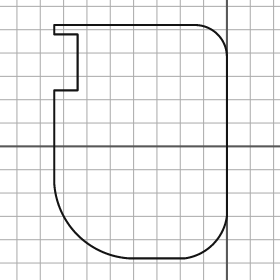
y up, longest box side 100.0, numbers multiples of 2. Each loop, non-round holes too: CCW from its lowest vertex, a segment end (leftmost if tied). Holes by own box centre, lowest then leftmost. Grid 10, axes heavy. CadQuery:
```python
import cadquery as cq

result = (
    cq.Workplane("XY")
    .moveTo(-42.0, -48.0)
    .lineTo(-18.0, -48.0)
    .threePointArc((-6.0, -42.0), (0.0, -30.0))
    .lineTo(0.0, 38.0)
    .threePointArc((-4.0, 48.0), (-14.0, 52.0))
    .lineTo(-74.0, 52.0)
    .lineTo(-74.0, 48.0)
    .lineTo(-64.0, 48.0)
    .lineTo(-64.0, 24.0)
    .lineTo(-74.0, 24.0)
    .lineTo(-74.0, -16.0)
    .threePointArc((-64.0, -38.0), (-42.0, -48.0))
    .close()
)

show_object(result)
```